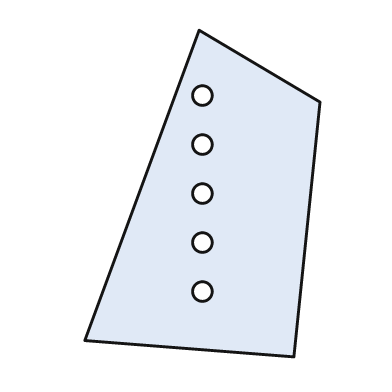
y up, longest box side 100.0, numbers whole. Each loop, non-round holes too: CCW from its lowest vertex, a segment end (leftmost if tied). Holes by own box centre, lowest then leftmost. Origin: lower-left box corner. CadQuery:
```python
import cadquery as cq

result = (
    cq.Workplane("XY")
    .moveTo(64.0, 0.0)
    .lineTo(72.0, 78.0)
    .lineTo(35.0, 100.0)
    .lineTo(0.0, 5.0)
    .close()
    .moveTo(36.0, 20.0)
    .circle(3.0)
    .moveTo(36.0, 35.0)
    .circle(3.0)
    .moveTo(36.0, 50.0)
    .circle(3.0)
    .moveTo(36.0, 65.0)
    .circle(3.0)
    .moveTo(36.0, 80.0)
    .circle(3.0)
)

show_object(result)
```